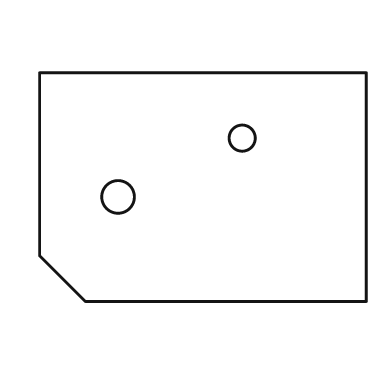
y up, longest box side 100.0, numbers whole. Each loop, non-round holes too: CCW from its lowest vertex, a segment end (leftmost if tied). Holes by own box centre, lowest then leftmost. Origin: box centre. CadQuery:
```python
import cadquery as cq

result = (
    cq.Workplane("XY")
    .moveTo(-36.0, -35.0)
    .lineTo(50.0, -35.0)
    .lineTo(50.0, 35.0)
    .lineTo(-50.0, 35.0)
    .lineTo(-50.0, -21.0)
    .close()
    .moveTo(-26.0, -3.0)
    .circle(5.0)
    .moveTo(12.0, 15.0)
    .circle(4.0)
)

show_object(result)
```